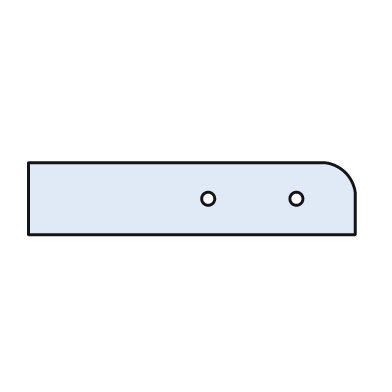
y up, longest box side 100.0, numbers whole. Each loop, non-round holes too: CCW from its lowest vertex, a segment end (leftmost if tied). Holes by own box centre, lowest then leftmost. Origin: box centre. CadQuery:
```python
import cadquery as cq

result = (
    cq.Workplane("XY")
    .moveTo(-50.0, -11.0)
    .lineTo(50.0, -11.0)
    .lineTo(50.0, 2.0)
    .threePointArc((47.0, 8.0), (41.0, 11.0))
    .lineTo(-50.0, 11.0)
    .close()
    .moveTo(5.0, 0.0)
    .circle(2.0)
    .moveTo(32.0, 0.0)
    .circle(2.0)
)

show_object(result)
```